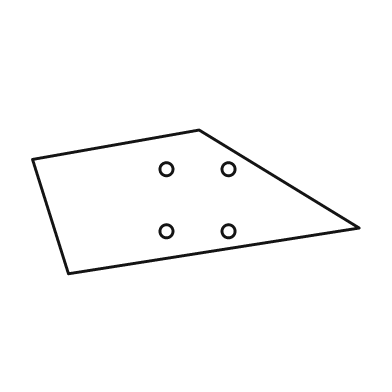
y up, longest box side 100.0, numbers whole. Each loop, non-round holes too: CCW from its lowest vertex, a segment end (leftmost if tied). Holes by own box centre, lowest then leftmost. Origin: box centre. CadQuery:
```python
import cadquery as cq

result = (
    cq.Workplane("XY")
    .moveTo(-39.0, -22.0)
    .lineTo(50.0, -8.0)
    .lineTo(1.0, 22.0)
    .lineTo(-50.0, 13.0)
    .close()
    .moveTo(-9.0, -9.0)
    .circle(2.0)
    .moveTo(10.0, -9.0)
    .circle(2.0)
    .moveTo(-9.0, 10.0)
    .circle(2.0)
    .moveTo(10.0, 10.0)
    .circle(2.0)
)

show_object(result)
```